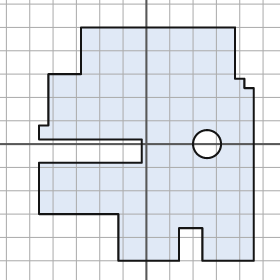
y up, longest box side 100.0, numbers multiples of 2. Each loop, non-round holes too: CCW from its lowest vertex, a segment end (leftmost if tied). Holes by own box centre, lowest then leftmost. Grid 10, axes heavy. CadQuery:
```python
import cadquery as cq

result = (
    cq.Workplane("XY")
    .moveTo(-12.0, -50.0)
    .lineTo(14.0, -50.0)
    .lineTo(14.0, -36.0)
    .lineTo(24.0, -36.0)
    .lineTo(24.0, -50.0)
    .lineTo(46.0, -50.0)
    .lineTo(46.0, 24.0)
    .lineTo(42.0, 24.0)
    .lineTo(42.0, 28.0)
    .lineTo(38.0, 28.0)
    .lineTo(38.0, 50.0)
    .lineTo(-28.0, 50.0)
    .lineTo(-28.0, 30.0)
    .lineTo(-42.0, 30.0)
    .lineTo(-42.0, 8.0)
    .lineTo(-46.0, 8.0)
    .lineTo(-46.0, 2.0)
    .lineTo(-2.0, 2.0)
    .lineTo(-2.0, -8.0)
    .lineTo(-46.0, -8.0)
    .lineTo(-46.0, -30.0)
    .lineTo(-12.0, -30.0)
    .close()
    .moveTo(26.0, 0.0)
    .circle(6.0)
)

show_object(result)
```